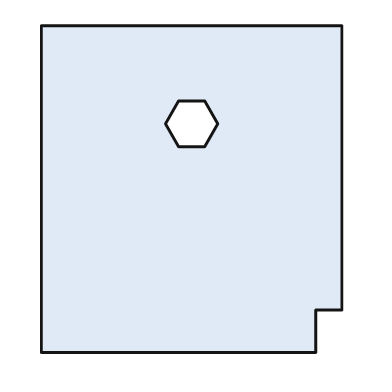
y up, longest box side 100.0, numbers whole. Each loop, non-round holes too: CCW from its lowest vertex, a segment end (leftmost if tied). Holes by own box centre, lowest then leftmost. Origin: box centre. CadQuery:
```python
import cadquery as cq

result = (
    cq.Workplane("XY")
    .moveTo(-46.0, -50.0)
    .lineTo(38.0, -50.0)
    .lineTo(38.0, -37.0)
    .lineTo(46.0, -37.0)
    .lineTo(46.0, 50.0)
    .lineTo(-46.0, 50.0)
    .close()
    .moveTo(-4.0, 13.0)
    .lineTo(4.0, 13.0)
    .lineTo(8.0, 20.0)
    .lineTo(4.0, 27.0)
    .lineTo(-4.0, 27.0)
    .lineTo(-8.0, 20.0)
    .close()
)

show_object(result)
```